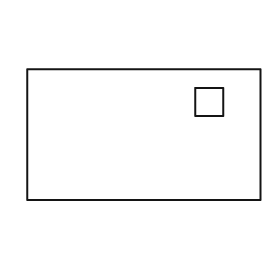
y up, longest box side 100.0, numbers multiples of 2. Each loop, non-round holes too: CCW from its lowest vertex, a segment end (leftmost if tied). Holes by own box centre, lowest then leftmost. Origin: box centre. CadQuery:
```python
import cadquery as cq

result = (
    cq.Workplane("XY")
    .moveTo(-50.0, -28.0)
    .lineTo(50.0, -28.0)
    .lineTo(50.0, 28.0)
    .lineTo(-50.0, 28.0)
    .close()
    .moveTo(22.0, 8.0)
    .lineTo(34.0, 8.0)
    .lineTo(34.0, 20.0)
    .lineTo(22.0, 20.0)
    .close()
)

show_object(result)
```